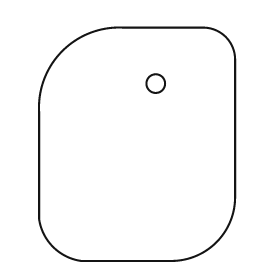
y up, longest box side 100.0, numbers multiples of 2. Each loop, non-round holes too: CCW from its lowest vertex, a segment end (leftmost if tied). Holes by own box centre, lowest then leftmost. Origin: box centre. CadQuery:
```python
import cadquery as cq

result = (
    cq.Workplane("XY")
    .moveTo(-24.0, -50.0)
    .lineTo(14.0, -50.0)
    .threePointArc((34.0, -42.0), (42.0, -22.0))
    .lineTo(42.0, 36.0)
    .threePointArc((38.0, 46.0), (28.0, 50.0))
    .lineTo(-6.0, 50.0)
    .threePointArc((-32.0, 40.0), (-42.0, 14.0))
    .lineTo(-42.0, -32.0)
    .threePointArc((-36.0, -44.0), (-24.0, -50.0))
    .close()
    .moveTo(8.0, 26.0)
    .circle(4.0)
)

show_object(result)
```